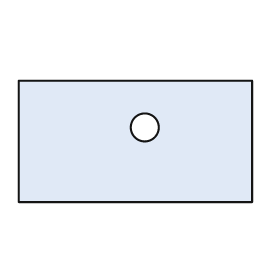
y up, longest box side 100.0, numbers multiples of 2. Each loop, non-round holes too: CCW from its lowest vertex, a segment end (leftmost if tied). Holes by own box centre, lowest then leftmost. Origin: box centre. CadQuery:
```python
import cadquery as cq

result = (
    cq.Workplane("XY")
    .moveTo(-50.0, -26.0)
    .lineTo(50.0, -26.0)
    .lineTo(50.0, 26.0)
    .lineTo(-50.0, 26.0)
    .close()
    .moveTo(4.0, 6.0)
    .circle(6.0)
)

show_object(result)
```